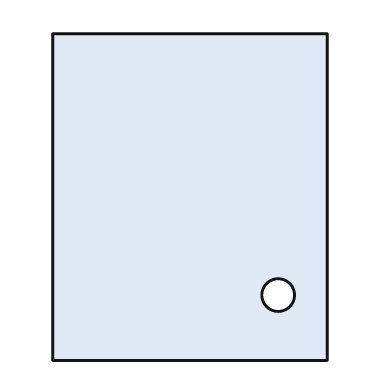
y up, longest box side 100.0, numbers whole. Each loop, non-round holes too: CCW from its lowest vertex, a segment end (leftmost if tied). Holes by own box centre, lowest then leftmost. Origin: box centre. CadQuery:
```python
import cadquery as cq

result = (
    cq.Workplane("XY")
    .moveTo(-42.0, -50.0)
    .lineTo(42.0, -50.0)
    .lineTo(42.0, 50.0)
    .lineTo(-42.0, 50.0)
    .close()
    .moveTo(27.0, -30.0)
    .circle(5.0)
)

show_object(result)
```